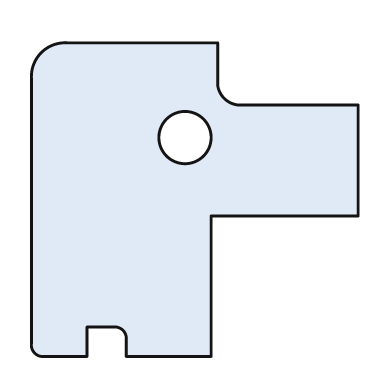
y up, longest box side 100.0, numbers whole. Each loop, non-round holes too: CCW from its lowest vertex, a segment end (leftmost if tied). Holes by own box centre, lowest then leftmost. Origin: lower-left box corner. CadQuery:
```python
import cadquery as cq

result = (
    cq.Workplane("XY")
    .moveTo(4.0, 0.0)
    .lineTo(17.0, 0.0)
    .lineTo(17.0, 9.0)
    .lineTo(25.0, 9.0)
    .threePointArc((28.0, 8.0), (29.0, 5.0))
    .lineTo(29.0, 0.0)
    .lineTo(55.0, 0.0)
    .lineTo(55.0, 43.0)
    .lineTo(100.0, 43.0)
    .lineTo(100.0, 77.0)
    .lineTo(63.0, 77.0)
    .threePointArc((59.0, 79.0), (57.0, 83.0))
    .lineTo(57.0, 96.0)
    .lineTo(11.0, 96.0)
    .threePointArc((3.0, 93.0), (0.0, 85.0))
    .lineTo(0.0, 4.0)
    .threePointArc((1.0, 1.0), (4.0, 0.0))
    .close()
    .moveTo(47.0, 67.0)
    .circle(8.0)
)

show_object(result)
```